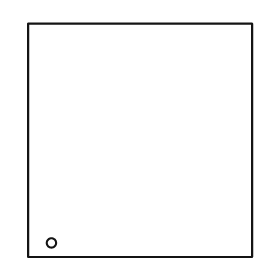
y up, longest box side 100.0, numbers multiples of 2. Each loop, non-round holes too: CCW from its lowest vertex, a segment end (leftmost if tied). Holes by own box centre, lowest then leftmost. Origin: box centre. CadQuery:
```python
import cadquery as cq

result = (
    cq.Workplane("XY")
    .moveTo(-48.0, -50.0)
    .lineTo(48.0, -50.0)
    .lineTo(48.0, 50.0)
    .lineTo(-48.0, 50.0)
    .close()
    .moveTo(-38.0, -44.0)
    .circle(2.0)
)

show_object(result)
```